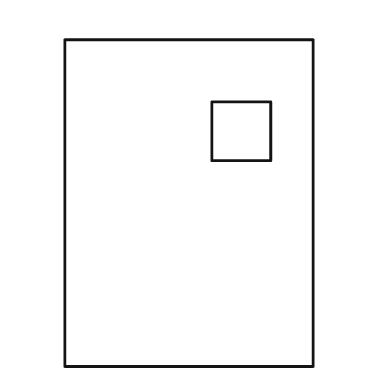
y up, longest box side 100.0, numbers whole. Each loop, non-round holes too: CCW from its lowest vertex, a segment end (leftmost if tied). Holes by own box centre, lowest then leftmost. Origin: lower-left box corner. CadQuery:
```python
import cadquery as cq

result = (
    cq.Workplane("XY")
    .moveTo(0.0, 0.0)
    .lineTo(76.0, 0.0)
    .lineTo(76.0, 100.0)
    .lineTo(0.0, 100.0)
    .close()
    .moveTo(45.0, 63.0)
    .lineTo(63.0, 63.0)
    .lineTo(63.0, 81.0)
    .lineTo(45.0, 81.0)
    .close()
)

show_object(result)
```